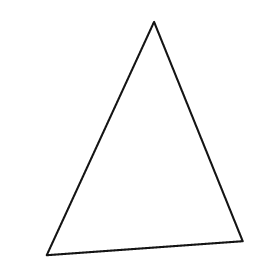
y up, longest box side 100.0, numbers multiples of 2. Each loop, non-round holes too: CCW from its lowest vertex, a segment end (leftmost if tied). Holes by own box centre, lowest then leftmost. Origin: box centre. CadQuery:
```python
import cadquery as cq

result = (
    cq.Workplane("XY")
    .moveTo(-42.0, -50.0)
    .lineTo(42.0, -44.0)
    .lineTo(4.0, 50.0)
    .close()
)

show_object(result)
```